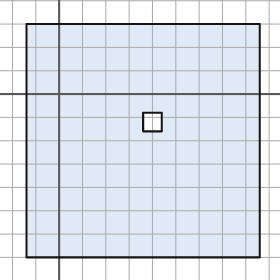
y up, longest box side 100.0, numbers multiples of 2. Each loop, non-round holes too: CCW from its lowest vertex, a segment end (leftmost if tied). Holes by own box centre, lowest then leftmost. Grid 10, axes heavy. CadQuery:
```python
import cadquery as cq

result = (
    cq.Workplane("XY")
    .moveTo(-14.0, -70.0)
    .lineTo(86.0, -70.0)
    .lineTo(86.0, 30.0)
    .lineTo(-14.0, 30.0)
    .close()
    .moveTo(36.0, -16.0)
    .lineTo(44.0, -16.0)
    .lineTo(44.0, -8.0)
    .lineTo(36.0, -8.0)
    .close()
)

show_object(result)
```